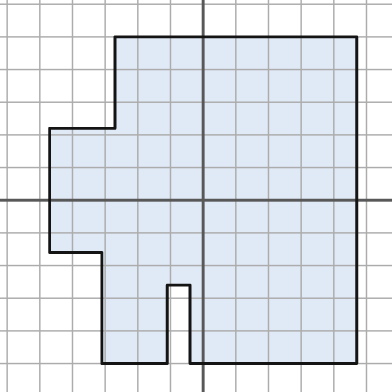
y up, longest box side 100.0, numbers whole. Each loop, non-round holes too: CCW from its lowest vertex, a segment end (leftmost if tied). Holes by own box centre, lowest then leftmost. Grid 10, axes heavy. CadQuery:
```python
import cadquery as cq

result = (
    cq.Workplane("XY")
    .moveTo(-31.0, -50.0)
    .lineTo(-11.0, -50.0)
    .lineTo(-11.0, -26.0)
    .lineTo(-4.0, -26.0)
    .lineTo(-4.0, -50.0)
    .lineTo(47.0, -50.0)
    .lineTo(47.0, 50.0)
    .lineTo(-27.0, 50.0)
    .lineTo(-27.0, 22.0)
    .lineTo(-47.0, 22.0)
    .lineTo(-47.0, -16.0)
    .lineTo(-31.0, -16.0)
    .close()
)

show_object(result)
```